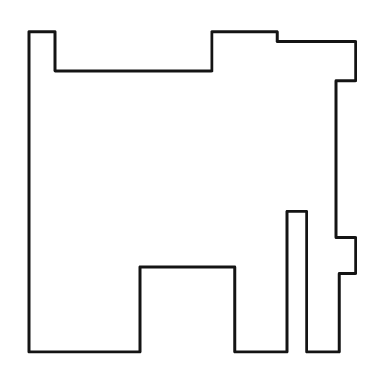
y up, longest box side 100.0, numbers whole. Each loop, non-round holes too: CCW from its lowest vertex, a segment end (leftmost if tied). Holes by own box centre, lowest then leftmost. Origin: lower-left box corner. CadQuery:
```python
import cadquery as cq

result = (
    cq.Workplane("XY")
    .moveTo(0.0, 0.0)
    .lineTo(34.0, 0.0)
    .lineTo(34.0, 26.0)
    .lineTo(63.0, 26.0)
    .lineTo(63.0, 0.0)
    .lineTo(79.0, 0.0)
    .lineTo(79.0, 43.0)
    .lineTo(85.0, 43.0)
    .lineTo(85.0, 0.0)
    .lineTo(95.0, 0.0)
    .lineTo(95.0, 24.0)
    .lineTo(100.0, 24.0)
    .lineTo(100.0, 35.0)
    .lineTo(94.0, 35.0)
    .lineTo(94.0, 83.0)
    .lineTo(100.0, 83.0)
    .lineTo(100.0, 95.0)
    .lineTo(76.0, 95.0)
    .lineTo(76.0, 98.0)
    .lineTo(56.0, 98.0)
    .lineTo(56.0, 86.0)
    .lineTo(8.0, 86.0)
    .lineTo(8.0, 98.0)
    .lineTo(0.0, 98.0)
    .close()
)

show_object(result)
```